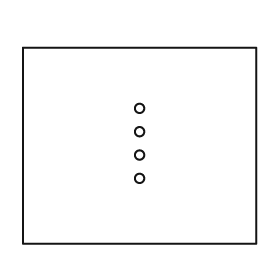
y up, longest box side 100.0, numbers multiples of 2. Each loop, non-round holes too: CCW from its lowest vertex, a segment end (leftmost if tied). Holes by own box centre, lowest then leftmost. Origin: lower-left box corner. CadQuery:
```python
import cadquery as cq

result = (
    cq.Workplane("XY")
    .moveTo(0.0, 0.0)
    .lineTo(100.0, 0.0)
    .lineTo(100.0, 84.0)
    .lineTo(0.0, 84.0)
    .close()
    .moveTo(50.0, 28.0)
    .circle(2.0)
    .moveTo(50.0, 38.0)
    .circle(2.0)
    .moveTo(50.0, 48.0)
    .circle(2.0)
    .moveTo(50.0, 58.0)
    .circle(2.0)
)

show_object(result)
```